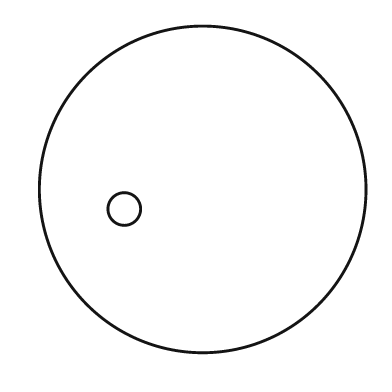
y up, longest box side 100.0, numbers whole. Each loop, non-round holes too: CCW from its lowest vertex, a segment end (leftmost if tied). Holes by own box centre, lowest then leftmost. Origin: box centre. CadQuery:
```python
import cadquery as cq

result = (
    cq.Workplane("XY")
    .moveTo(0.0, 0.0)
    .circle(50.0)
    .moveTo(-24.0, -6.0)
    .circle(5.0)
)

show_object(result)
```